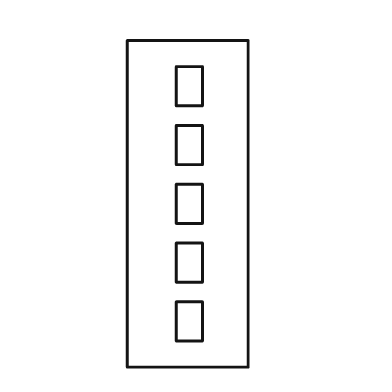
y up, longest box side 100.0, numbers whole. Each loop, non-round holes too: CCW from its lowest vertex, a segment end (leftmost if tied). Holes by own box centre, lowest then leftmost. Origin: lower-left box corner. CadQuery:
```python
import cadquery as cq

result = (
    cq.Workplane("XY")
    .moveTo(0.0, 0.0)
    .lineTo(37.0, 0.0)
    .lineTo(37.0, 100.0)
    .lineTo(0.0, 100.0)
    .close()
    .moveTo(15.0, 8.0)
    .lineTo(23.0, 8.0)
    .lineTo(23.0, 20.0)
    .lineTo(15.0, 20.0)
    .close()
    .moveTo(15.0, 26.0)
    .lineTo(23.0, 26.0)
    .lineTo(23.0, 38.0)
    .lineTo(15.0, 38.0)
    .close()
    .moveTo(15.0, 44.0)
    .lineTo(23.0, 44.0)
    .lineTo(23.0, 56.0)
    .lineTo(15.0, 56.0)
    .close()
    .moveTo(15.0, 62.0)
    .lineTo(23.0, 62.0)
    .lineTo(23.0, 74.0)
    .lineTo(15.0, 74.0)
    .close()
    .moveTo(15.0, 80.0)
    .lineTo(23.0, 80.0)
    .lineTo(23.0, 92.0)
    .lineTo(15.0, 92.0)
    .close()
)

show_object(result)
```